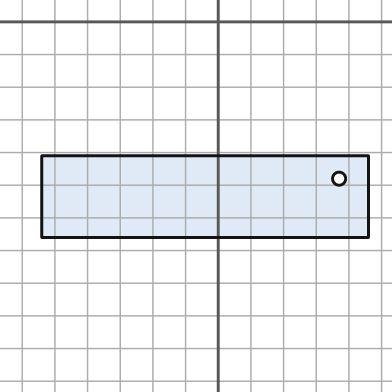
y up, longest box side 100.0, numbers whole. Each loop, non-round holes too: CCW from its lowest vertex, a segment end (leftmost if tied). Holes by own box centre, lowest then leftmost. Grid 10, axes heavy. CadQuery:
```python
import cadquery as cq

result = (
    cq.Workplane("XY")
    .moveTo(-54.0, -66.0)
    .lineTo(46.0, -66.0)
    .lineTo(46.0, -41.0)
    .lineTo(-54.0, -41.0)
    .close()
    .moveTo(37.0, -48.0)
    .circle(2.0)
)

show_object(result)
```